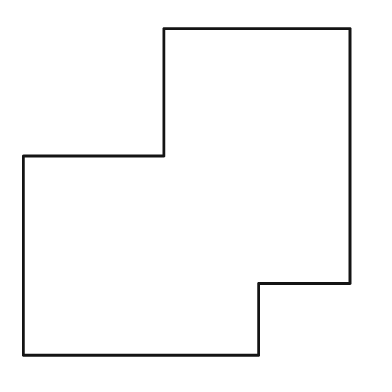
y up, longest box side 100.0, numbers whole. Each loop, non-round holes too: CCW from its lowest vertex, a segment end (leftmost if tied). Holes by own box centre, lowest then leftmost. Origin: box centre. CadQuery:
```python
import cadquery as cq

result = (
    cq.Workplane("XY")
    .moveTo(-50.0, -50.0)
    .lineTo(22.0, -50.0)
    .lineTo(22.0, -28.0)
    .lineTo(50.0, -28.0)
    .lineTo(50.0, 50.0)
    .lineTo(-7.0, 50.0)
    .lineTo(-7.0, 11.0)
    .lineTo(-50.0, 11.0)
    .close()
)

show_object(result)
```